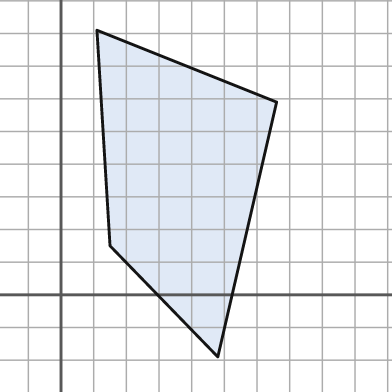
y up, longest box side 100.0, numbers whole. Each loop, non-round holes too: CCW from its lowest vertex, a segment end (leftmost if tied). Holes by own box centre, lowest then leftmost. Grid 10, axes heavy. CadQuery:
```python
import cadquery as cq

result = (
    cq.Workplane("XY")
    .moveTo(48.0, -19.0)
    .lineTo(66.0, 59.0)
    .lineTo(11.0, 81.0)
    .lineTo(15.0, 15.0)
    .close()
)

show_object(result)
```